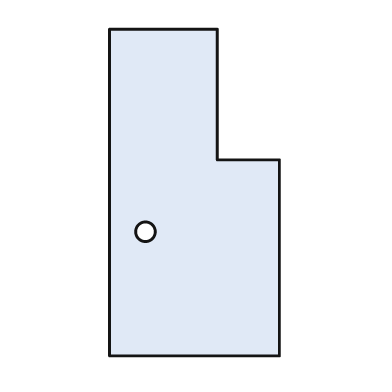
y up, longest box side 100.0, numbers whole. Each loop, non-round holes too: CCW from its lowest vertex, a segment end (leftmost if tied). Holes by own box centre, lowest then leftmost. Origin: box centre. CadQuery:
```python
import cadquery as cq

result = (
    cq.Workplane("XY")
    .moveTo(-26.0, -50.0)
    .lineTo(26.0, -50.0)
    .lineTo(26.0, 10.0)
    .lineTo(7.0, 10.0)
    .lineTo(7.0, 50.0)
    .lineTo(-26.0, 50.0)
    .close()
    .moveTo(-15.0, -12.0)
    .circle(3.0)
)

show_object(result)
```